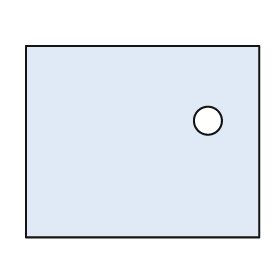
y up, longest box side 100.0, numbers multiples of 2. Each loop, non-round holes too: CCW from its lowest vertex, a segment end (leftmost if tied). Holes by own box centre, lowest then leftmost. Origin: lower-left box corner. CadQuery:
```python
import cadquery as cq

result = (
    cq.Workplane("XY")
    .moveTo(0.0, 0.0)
    .lineTo(100.0, 0.0)
    .lineTo(100.0, 82.0)
    .lineTo(0.0, 82.0)
    .close()
    .moveTo(78.0, 50.0)
    .circle(6.0)
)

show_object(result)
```